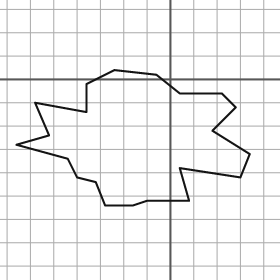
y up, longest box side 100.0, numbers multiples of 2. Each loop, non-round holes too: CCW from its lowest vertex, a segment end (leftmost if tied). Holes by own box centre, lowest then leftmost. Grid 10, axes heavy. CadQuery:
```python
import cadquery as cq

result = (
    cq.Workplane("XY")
    .moveTo(-28.0, -54.0)
    .lineTo(-16.0, -54.0)
    .lineTo(-10.0, -52.0)
    .lineTo(8.0, -52.0)
    .lineTo(4.0, -38.0)
    .lineTo(30.0, -42.0)
    .lineTo(34.0, -32.0)
    .lineTo(18.0, -22.0)
    .lineTo(28.0, -12.0)
    .lineTo(22.0, -6.0)
    .lineTo(4.0, -6.0)
    .lineTo(-6.0, 2.0)
    .lineTo(-24.0, 4.0)
    .lineTo(-36.0, -2.0)
    .lineTo(-36.0, -14.0)
    .lineTo(-58.0, -10.0)
    .lineTo(-52.0, -24.0)
    .lineTo(-66.0, -28.0)
    .lineTo(-44.0, -34.0)
    .lineTo(-40.0, -42.0)
    .lineTo(-32.0, -44.0)
    .close()
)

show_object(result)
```